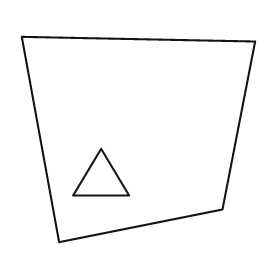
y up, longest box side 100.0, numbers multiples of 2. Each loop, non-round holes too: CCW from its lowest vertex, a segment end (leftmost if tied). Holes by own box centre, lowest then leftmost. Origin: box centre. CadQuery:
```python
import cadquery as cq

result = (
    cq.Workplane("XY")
    .moveTo(-34.0, -44.0)
    .lineTo(36.0, -30.0)
    .lineTo(50.0, 42.0)
    .lineTo(-50.0, 44.0)
    .close()
    .moveTo(-28.0, -24.0)
    .lineTo(-4.0, -24.0)
    .lineTo(-16.0, -4.0)
    .close()
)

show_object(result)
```